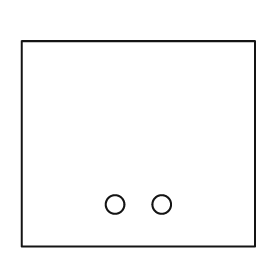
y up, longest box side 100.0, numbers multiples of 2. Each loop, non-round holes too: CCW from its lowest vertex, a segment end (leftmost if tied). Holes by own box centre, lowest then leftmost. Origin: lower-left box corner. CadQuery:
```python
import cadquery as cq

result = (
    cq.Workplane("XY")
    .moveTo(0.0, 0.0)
    .lineTo(100.0, 0.0)
    .lineTo(100.0, 88.0)
    .lineTo(0.0, 88.0)
    .close()
    .moveTo(40.0, 18.0)
    .circle(4.0)
    .moveTo(60.0, 18.0)
    .circle(4.0)
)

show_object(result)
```